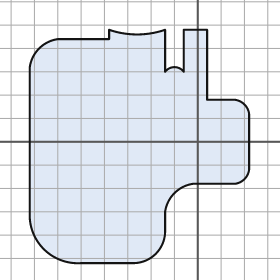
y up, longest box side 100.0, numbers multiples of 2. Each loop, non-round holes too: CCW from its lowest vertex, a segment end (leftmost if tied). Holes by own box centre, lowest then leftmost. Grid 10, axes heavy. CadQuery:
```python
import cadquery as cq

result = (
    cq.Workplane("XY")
    .moveTo(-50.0, -52.0)
    .lineTo(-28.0, -52.0)
    .threePointArc((-18.0, -48.0), (-14.0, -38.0))
    .lineTo(-14.0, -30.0)
    .threePointArc((-10.0, -22.0), (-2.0, -18.0))
    .lineTo(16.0, -18.0)
    .threePointArc((20.0, -16.0), (22.0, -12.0))
    .lineTo(22.0, 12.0)
    .threePointArc((20.0, 16.0), (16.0, 18.0))
    .lineTo(4.0, 18.0)
    .lineTo(4.0, 48.0)
    .lineTo(-6.0, 48.0)
    .lineTo(-6.0, 30.0)
    .threePointArc((-10.0, 32.0), (-14.0, 30.0))
    .lineTo(-14.0, 48.0)
    .threePointArc((-26.0, 46.0), (-38.0, 48.0))
    .lineTo(-38.0, 44.0)
    .lineTo(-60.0, 44.0)
    .threePointArc((-68.0, 40.0), (-72.0, 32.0))
    .lineTo(-72.0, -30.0)
    .threePointArc((-66.0, -46.0), (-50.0, -52.0))
    .close()
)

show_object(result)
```